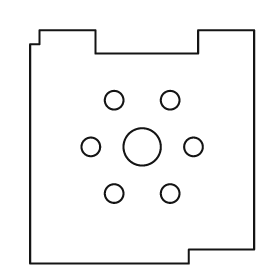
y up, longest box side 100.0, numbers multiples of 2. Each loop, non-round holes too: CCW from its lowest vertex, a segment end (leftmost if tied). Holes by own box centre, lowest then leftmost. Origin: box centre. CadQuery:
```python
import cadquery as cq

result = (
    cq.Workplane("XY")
    .moveTo(-48.0, -50.0)
    .lineTo(20.0, -50.0)
    .lineTo(20.0, -44.0)
    .lineTo(48.0, -44.0)
    .lineTo(48.0, 50.0)
    .lineTo(24.0, 50.0)
    .lineTo(24.0, 40.0)
    .lineTo(-20.0, 40.0)
    .lineTo(-20.0, 50.0)
    .lineTo(-44.0, 50.0)
    .lineTo(-44.0, 44.0)
    .lineTo(-48.0, 44.0)
    .close()
    .moveTo(-12.0, -20.0)
    .circle(4.0)
    .moveTo(12.0, -20.0)
    .circle(4.0)
    .moveTo(-22.0, 0.0)
    .circle(4.0)
    .moveTo(0.0, 0.0)
    .circle(8.0)
    .moveTo(22.0, 0.0)
    .circle(4.0)
    .moveTo(-12.0, 20.0)
    .circle(4.0)
    .moveTo(12.0, 20.0)
    .circle(4.0)
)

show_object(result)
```